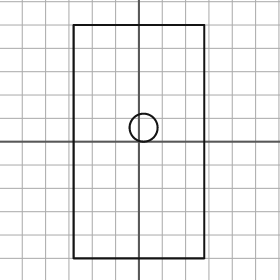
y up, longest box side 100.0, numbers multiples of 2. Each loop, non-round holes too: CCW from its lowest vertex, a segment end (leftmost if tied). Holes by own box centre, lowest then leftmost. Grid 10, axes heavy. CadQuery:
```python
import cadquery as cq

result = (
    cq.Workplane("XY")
    .moveTo(-28.0, -50.0)
    .lineTo(28.0, -50.0)
    .lineTo(28.0, 50.0)
    .lineTo(-28.0, 50.0)
    .close()
    .moveTo(2.0, 6.0)
    .circle(6.0)
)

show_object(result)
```